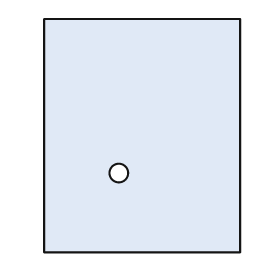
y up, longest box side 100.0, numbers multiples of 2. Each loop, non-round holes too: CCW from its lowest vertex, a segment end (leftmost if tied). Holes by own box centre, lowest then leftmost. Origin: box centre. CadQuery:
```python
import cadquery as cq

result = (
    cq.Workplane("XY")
    .moveTo(-42.0, -50.0)
    .lineTo(42.0, -50.0)
    .lineTo(42.0, 50.0)
    .lineTo(-42.0, 50.0)
    .close()
    .moveTo(-10.0, -16.0)
    .circle(4.0)
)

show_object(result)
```